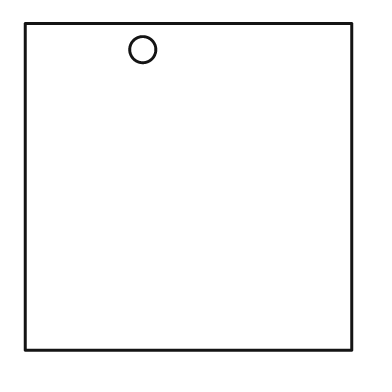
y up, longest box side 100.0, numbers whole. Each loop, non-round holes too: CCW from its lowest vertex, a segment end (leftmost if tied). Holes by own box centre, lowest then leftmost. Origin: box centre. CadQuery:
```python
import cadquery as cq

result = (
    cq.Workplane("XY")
    .moveTo(-50.0, -50.0)
    .lineTo(50.0, -50.0)
    .lineTo(50.0, 50.0)
    .lineTo(-50.0, 50.0)
    .close()
    .moveTo(-14.0, 42.0)
    .circle(4.0)
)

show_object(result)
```